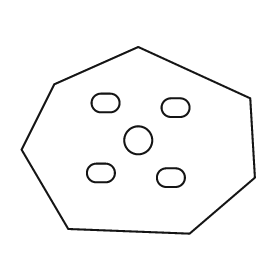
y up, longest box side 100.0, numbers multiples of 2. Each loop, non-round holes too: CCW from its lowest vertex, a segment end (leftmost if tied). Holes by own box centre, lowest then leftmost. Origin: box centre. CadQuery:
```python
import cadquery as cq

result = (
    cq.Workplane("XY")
    .moveTo(22.0, -40.0)
    .lineTo(50.0, -16.0)
    .lineTo(48.0, 18.0)
    .lineTo(0.0, 40.0)
    .lineTo(-36.0, 24.0)
    .lineTo(-50.0, -4.0)
    .lineTo(-30.0, -38.0)
    .close()
    .moveTo(12.0, -20.0)
    .lineTo(16.0, -20.0)
    .threePointArc((20.0, -16.0), (16.0, -12.0))
    .lineTo(12.0, -12.0)
    .threePointArc((8.0, -16.0), (12.0, -20.0))
    .close()
    .moveTo(-18.0, -18.0)
    .lineTo(-14.0, -18.0)
    .threePointArc((-10.0, -14.0), (-14.0, -10.0))
    .lineTo(-18.0, -10.0)
    .threePointArc((-22.0, -14.0), (-18.0, -18.0))
    .close()
    .moveTo(0.0, 0.0)
    .circle(6.0)
    .moveTo(14.0, 10.0)
    .lineTo(18.0, 10.0)
    .threePointArc((22.0, 14.0), (18.0, 18.0))
    .lineTo(14.0, 18.0)
    .threePointArc((10.0, 14.0), (14.0, 10.0))
    .close()
    .moveTo(-16.0, 12.0)
    .lineTo(-12.0, 12.0)
    .threePointArc((-8.0, 16.0), (-12.0, 20.0))
    .lineTo(-16.0, 20.0)
    .threePointArc((-20.0, 16.0), (-16.0, 12.0))
    .close()
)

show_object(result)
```